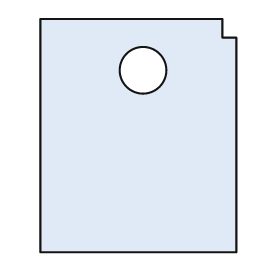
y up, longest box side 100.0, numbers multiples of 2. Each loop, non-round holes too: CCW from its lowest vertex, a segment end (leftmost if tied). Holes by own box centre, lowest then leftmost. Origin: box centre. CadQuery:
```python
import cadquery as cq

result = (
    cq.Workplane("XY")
    .moveTo(-42.0, -50.0)
    .lineTo(42.0, -50.0)
    .lineTo(42.0, 42.0)
    .lineTo(36.0, 42.0)
    .lineTo(36.0, 50.0)
    .lineTo(-42.0, 50.0)
    .close()
    .moveTo(2.0, 28.0)
    .circle(10.0)
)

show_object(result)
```